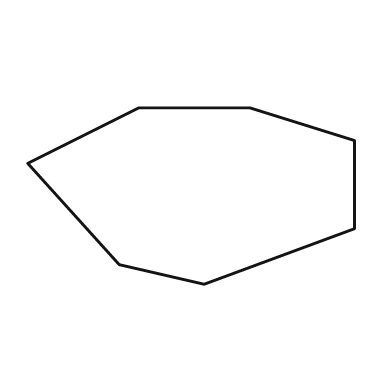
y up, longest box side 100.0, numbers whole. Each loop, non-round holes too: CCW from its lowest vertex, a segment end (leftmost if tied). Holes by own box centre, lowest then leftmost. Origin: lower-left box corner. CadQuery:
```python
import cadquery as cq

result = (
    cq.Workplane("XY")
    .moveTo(54.0, 0.0)
    .lineTo(100.0, 17.0)
    .lineTo(100.0, 44.0)
    .lineTo(68.0, 54.0)
    .lineTo(34.0, 54.0)
    .lineTo(0.0, 37.0)
    .lineTo(28.0, 6.0)
    .close()
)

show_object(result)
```